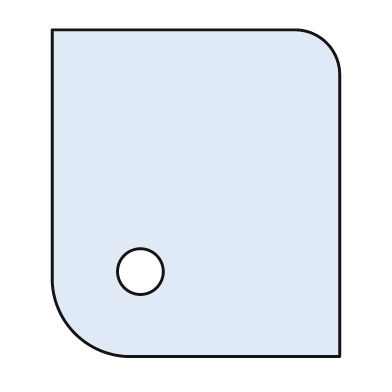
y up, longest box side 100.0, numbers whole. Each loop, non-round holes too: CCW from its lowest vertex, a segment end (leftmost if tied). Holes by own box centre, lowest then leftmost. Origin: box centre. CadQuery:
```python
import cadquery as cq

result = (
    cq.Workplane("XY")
    .moveTo(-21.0, -50.0)
    .lineTo(44.0, -50.0)
    .lineTo(44.0, 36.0)
    .threePointArc((40.0, 46.0), (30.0, 50.0))
    .lineTo(-44.0, 50.0)
    .lineTo(-44.0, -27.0)
    .threePointArc((-37.0, -43.0), (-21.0, -50.0))
    .close()
    .moveTo(-17.0, -24.0)
    .circle(7.0)
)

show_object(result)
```